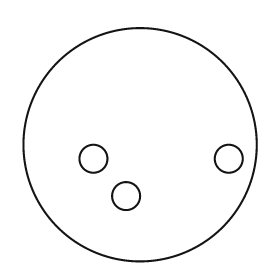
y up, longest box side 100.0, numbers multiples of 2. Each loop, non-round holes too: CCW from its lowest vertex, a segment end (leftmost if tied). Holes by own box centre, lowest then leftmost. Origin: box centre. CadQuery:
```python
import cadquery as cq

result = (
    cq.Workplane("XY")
    .moveTo(0.0, 0.0)
    .circle(50.0)
    .moveTo(-6.0, -22.0)
    .circle(6.0)
    .moveTo(-20.0, -6.0)
    .circle(6.0)
    .moveTo(38.0, -6.0)
    .circle(6.0)
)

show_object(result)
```